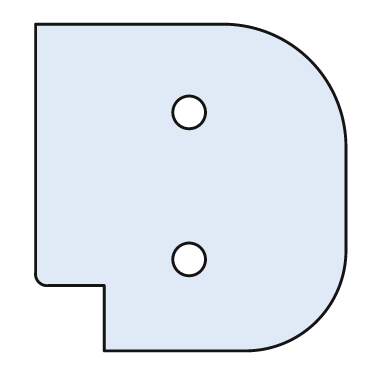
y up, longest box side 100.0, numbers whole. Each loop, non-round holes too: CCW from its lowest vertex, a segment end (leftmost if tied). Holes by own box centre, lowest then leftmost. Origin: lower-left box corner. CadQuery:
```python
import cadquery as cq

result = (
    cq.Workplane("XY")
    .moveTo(21.0, 0.0)
    .lineTo(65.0, 0.0)
    .threePointArc((86.0, 9.0), (95.0, 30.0))
    .lineTo(95.0, 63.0)
    .threePointArc((84.0, 89.0), (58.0, 100.0))
    .lineTo(0.0, 100.0)
    .lineTo(0.0, 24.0)
    .threePointArc((1.0, 21.0), (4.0, 20.0))
    .lineTo(21.0, 20.0)
    .close()
    .moveTo(47.0, 28.0)
    .circle(5.0)
    .moveTo(47.0, 73.0)
    .circle(5.0)
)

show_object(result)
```